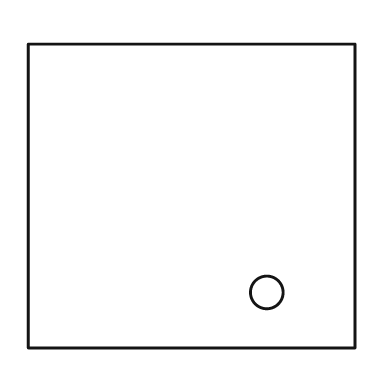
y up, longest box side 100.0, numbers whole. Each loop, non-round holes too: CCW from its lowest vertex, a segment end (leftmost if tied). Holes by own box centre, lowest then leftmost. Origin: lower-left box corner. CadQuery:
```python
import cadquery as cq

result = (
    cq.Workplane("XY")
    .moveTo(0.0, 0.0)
    .lineTo(100.0, 0.0)
    .lineTo(100.0, 93.0)
    .lineTo(0.0, 93.0)
    .close()
    .moveTo(73.0, 17.0)
    .circle(5.0)
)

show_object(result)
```